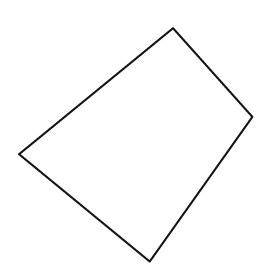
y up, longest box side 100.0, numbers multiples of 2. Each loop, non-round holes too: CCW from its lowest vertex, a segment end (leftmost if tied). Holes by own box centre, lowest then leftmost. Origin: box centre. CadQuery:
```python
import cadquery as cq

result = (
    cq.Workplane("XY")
    .moveTo(6.0, -50.0)
    .lineTo(50.0, 12.0)
    .lineTo(16.0, 50.0)
    .lineTo(-50.0, -4.0)
    .close()
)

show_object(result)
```